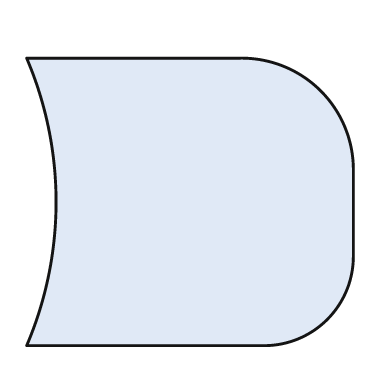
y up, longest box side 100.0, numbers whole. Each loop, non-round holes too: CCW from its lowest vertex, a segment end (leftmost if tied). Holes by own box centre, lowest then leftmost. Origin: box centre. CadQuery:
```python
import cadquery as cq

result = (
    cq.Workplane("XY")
    .moveTo(-50.0, -44.0)
    .lineTo(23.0, -44.0)
    .threePointArc((42.0, -36.0), (50.0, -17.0))
    .lineTo(50.0, 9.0)
    .threePointArc((40.0, 34.0), (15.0, 44.0))
    .lineTo(-50.0, 44.0)
    .threePointArc((-41.0, 0.0), (-50.0, -44.0))
    .close()
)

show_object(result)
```